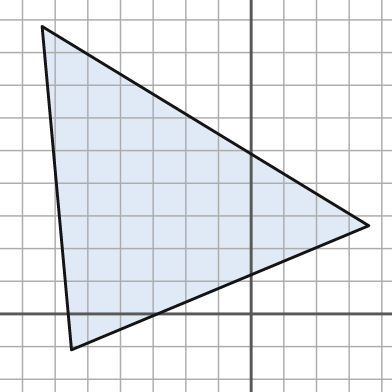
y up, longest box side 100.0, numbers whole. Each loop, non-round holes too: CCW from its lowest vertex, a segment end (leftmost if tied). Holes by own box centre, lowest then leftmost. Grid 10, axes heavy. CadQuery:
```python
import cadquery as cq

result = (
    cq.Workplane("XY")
    .moveTo(-55.0, -11.0)
    .lineTo(36.0, 27.0)
    .lineTo(-64.0, 88.0)
    .close()
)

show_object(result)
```